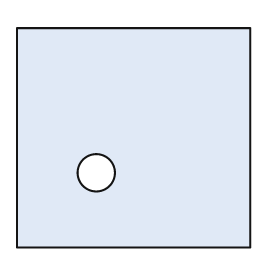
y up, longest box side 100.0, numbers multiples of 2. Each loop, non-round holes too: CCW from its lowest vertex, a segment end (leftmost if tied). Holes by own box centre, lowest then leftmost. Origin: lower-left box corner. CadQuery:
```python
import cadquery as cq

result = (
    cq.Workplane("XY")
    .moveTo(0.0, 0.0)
    .lineTo(100.0, 0.0)
    .lineTo(100.0, 94.0)
    .lineTo(0.0, 94.0)
    .close()
    .moveTo(34.0, 32.0)
    .circle(8.0)
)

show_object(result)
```